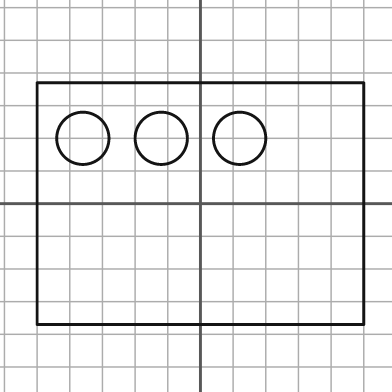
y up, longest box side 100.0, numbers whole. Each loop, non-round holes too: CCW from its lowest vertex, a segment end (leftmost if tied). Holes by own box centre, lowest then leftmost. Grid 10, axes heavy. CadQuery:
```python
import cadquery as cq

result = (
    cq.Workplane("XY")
    .moveTo(-50.0, -37.0)
    .lineTo(50.0, -37.0)
    .lineTo(50.0, 37.0)
    .lineTo(-50.0, 37.0)
    .close()
    .moveTo(-36.0, 20.0)
    .circle(8.0)
    .moveTo(-12.0, 20.0)
    .circle(8.0)
    .moveTo(12.0, 20.0)
    .circle(8.0)
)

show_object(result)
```